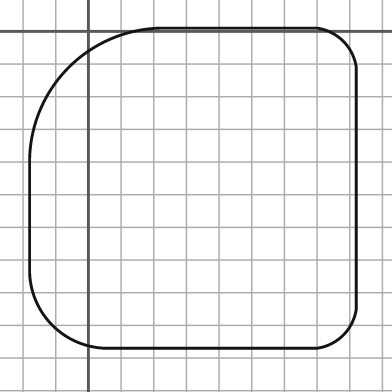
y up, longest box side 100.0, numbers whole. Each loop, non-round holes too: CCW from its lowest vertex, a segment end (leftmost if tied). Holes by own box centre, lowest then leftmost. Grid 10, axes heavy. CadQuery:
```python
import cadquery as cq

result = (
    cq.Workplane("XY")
    .moveTo(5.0, -97.0)
    .lineTo(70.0, -97.0)
    .threePointArc((78.0, -93.0), (82.0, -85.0))
    .lineTo(82.0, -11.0)
    .threePointArc((78.0, -3.0), (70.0, 1.0))
    .lineTo(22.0, 1.0)
    .threePointArc((-6.0, -11.0), (-18.0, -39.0))
    .lineTo(-18.0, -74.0)
    .threePointArc((-11.0, -90.0), (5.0, -97.0))
    .close()
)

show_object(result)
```